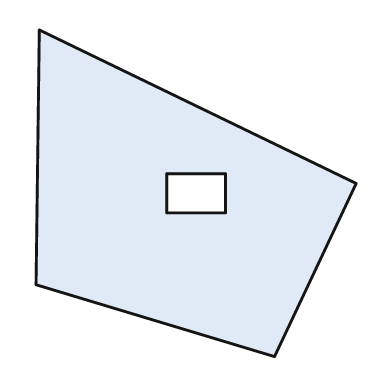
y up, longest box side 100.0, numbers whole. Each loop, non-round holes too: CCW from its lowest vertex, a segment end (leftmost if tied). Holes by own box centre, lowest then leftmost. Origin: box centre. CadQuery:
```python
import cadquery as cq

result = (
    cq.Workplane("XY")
    .moveTo(24.0, -50.0)
    .lineTo(49.0, 3.0)
    .lineTo(-48.0, 50.0)
    .lineTo(-49.0, -28.0)
    .close()
    .moveTo(-9.0, -6.0)
    .lineTo(9.0, -6.0)
    .lineTo(9.0, 6.0)
    .lineTo(-9.0, 6.0)
    .close()
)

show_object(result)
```